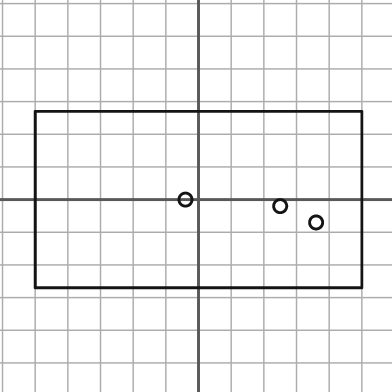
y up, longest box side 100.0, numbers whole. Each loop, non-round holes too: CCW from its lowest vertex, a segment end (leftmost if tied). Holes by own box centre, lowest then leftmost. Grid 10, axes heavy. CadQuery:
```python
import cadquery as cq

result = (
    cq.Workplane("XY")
    .moveTo(-50.0, -27.0)
    .lineTo(50.0, -27.0)
    .lineTo(50.0, 27.0)
    .lineTo(-50.0, 27.0)
    .close()
    .moveTo(36.0, -7.0)
    .circle(2.0)
    .moveTo(25.0, -2.0)
    .circle(2.0)
    .moveTo(-4.0, 0.0)
    .circle(2.0)
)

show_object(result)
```